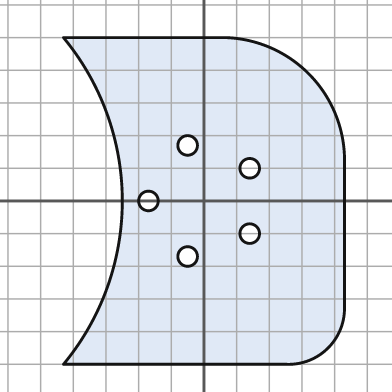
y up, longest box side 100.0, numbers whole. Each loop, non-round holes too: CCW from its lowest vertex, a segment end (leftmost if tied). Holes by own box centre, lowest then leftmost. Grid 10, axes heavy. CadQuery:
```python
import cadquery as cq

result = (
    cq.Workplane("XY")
    .moveTo(-43.0, -50.0)
    .lineTo(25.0, -50.0)
    .threePointArc((38.0, -45.0), (43.0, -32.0))
    .lineTo(43.0, 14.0)
    .threePointArc((32.0, 39.0), (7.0, 50.0))
    .lineTo(-43.0, 50.0)
    .threePointArc((-25.0, 0.0), (-43.0, -50.0))
    .close()
    .moveTo(-5.0, -17.0)
    .circle(3.0)
    .moveTo(14.0, -10.0)
    .circle(3.0)
    .moveTo(-17.0, 0.0)
    .circle(3.0)
    .moveTo(14.0, 10.0)
    .circle(3.0)
    .moveTo(-5.0, 17.0)
    .circle(3.0)
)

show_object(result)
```